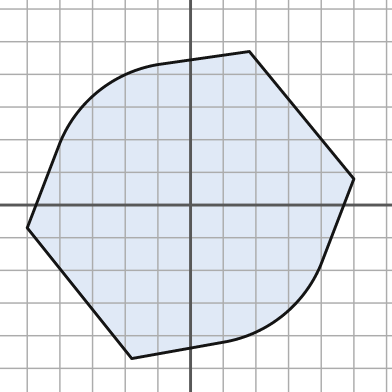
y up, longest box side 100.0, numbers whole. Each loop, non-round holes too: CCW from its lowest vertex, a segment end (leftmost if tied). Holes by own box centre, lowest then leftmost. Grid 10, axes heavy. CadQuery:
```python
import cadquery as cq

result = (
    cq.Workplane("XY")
    .moveTo(-18.0, -47.0)
    .lineTo(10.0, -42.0)
    .threePointArc((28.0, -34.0), (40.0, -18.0))
    .lineTo(50.0, 8.0)
    .lineTo(18.0, 47.0)
    .lineTo(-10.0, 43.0)
    .threePointArc((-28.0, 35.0), (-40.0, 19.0))
    .lineTo(-50.0, -7.0)
    .close()
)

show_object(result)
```